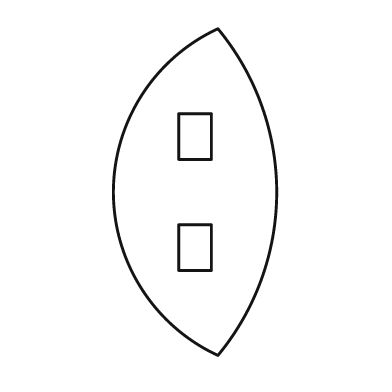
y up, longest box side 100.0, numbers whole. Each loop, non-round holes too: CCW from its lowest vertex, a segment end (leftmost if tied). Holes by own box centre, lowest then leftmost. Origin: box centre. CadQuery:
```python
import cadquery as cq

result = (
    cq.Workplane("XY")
    .moveTo(7.0, -50.0)
    .threePointArc((25.0, 0.0), (7.0, 50.0))
    .threePointArc((-25.0, 0.0), (7.0, -50.0))
    .close()
    .moveTo(-5.0, -24.0)
    .lineTo(5.0, -24.0)
    .lineTo(5.0, -10.0)
    .lineTo(-5.0, -10.0)
    .close()
    .moveTo(-5.0, 10.0)
    .lineTo(5.0, 10.0)
    .lineTo(5.0, 24.0)
    .lineTo(-5.0, 24.0)
    .close()
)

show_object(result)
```